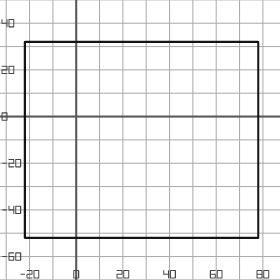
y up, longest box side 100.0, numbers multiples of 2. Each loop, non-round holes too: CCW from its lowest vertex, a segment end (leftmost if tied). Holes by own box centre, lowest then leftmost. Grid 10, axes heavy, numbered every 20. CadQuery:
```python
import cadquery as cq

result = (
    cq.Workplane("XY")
    .moveTo(-22.0, -52.0)
    .lineTo(78.0, -52.0)
    .lineTo(78.0, 32.0)
    .lineTo(-22.0, 32.0)
    .close()
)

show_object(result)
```